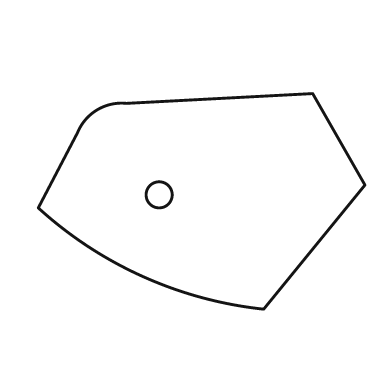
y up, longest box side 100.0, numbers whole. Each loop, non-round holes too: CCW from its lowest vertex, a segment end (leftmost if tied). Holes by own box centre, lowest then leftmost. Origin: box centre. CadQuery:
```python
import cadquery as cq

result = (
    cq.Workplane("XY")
    .moveTo(19.0, -33.0)
    .lineTo(50.0, 5.0)
    .lineTo(34.0, 33.0)
    .lineTo(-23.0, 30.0)
    .threePointArc((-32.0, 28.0), (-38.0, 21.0))
    .lineTo(-50.0, -2.0)
    .threePointArc((-18.0, -23.0), (19.0, -33.0))
    .close()
    .moveTo(-13.0, 2.0)
    .circle(4.0)
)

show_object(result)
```